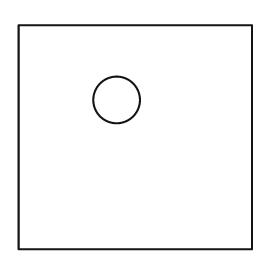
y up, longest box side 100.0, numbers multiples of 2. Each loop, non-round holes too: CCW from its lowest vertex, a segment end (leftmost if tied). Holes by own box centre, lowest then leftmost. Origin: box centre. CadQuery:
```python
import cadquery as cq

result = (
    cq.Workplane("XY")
    .moveTo(-50.0, -48.0)
    .lineTo(50.0, -48.0)
    .lineTo(50.0, 48.0)
    .lineTo(-50.0, 48.0)
    .close()
    .moveTo(-8.0, 16.0)
    .circle(10.0)
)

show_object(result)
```